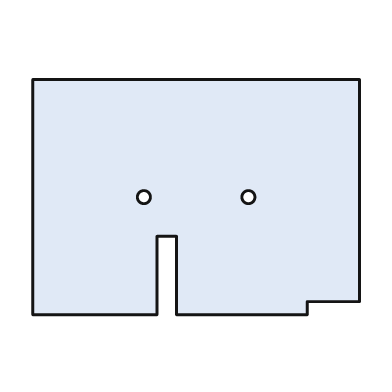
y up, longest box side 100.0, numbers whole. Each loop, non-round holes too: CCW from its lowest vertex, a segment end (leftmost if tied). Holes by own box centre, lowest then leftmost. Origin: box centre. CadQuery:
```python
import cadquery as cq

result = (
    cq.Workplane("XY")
    .moveTo(-50.0, -36.0)
    .lineTo(-12.0, -36.0)
    .lineTo(-12.0, -12.0)
    .lineTo(-6.0, -12.0)
    .lineTo(-6.0, -36.0)
    .lineTo(34.0, -36.0)
    .lineTo(34.0, -32.0)
    .lineTo(50.0, -32.0)
    .lineTo(50.0, 36.0)
    .lineTo(-50.0, 36.0)
    .close()
    .moveTo(-16.0, 0.0)
    .circle(2.0)
    .moveTo(16.0, 0.0)
    .circle(2.0)
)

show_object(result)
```